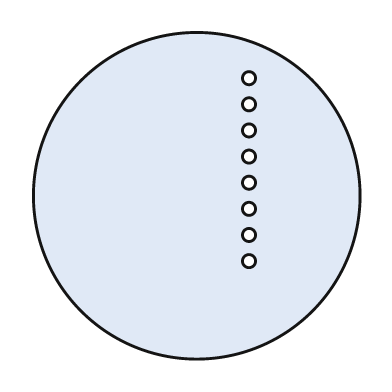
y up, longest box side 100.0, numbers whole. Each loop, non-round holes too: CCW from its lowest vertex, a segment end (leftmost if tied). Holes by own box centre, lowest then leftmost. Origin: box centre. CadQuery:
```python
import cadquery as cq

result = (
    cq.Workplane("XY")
    .moveTo(0.0, 0.0)
    .circle(50.0)
    .moveTo(16.0, -20.0)
    .circle(2.0)
    .moveTo(16.0, -12.0)
    .circle(2.0)
    .moveTo(16.0, -4.0)
    .circle(2.0)
    .moveTo(16.0, 4.0)
    .circle(2.0)
    .moveTo(16.0, 12.0)
    .circle(2.0)
    .moveTo(16.0, 20.0)
    .circle(2.0)
    .moveTo(16.0, 28.0)
    .circle(2.0)
    .moveTo(16.0, 36.0)
    .circle(2.0)
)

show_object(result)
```